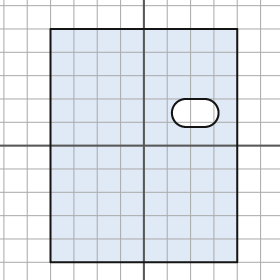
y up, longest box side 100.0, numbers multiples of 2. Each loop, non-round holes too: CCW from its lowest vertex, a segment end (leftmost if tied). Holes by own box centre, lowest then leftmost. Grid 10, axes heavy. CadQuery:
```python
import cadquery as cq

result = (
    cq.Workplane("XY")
    .moveTo(-40.0, -50.0)
    .lineTo(40.0, -50.0)
    .lineTo(40.0, 50.0)
    .lineTo(-40.0, 50.0)
    .close()
    .moveTo(18.0, 8.0)
    .lineTo(26.0, 8.0)
    .threePointArc((32.0, 14.0), (26.0, 20.0))
    .lineTo(18.0, 20.0)
    .threePointArc((12.0, 14.0), (18.0, 8.0))
    .close()
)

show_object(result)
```